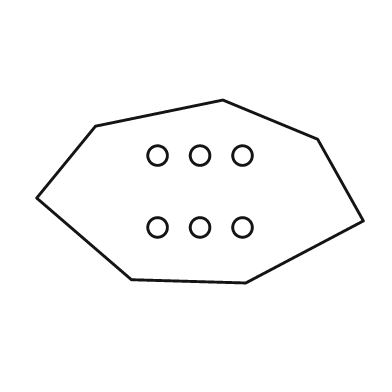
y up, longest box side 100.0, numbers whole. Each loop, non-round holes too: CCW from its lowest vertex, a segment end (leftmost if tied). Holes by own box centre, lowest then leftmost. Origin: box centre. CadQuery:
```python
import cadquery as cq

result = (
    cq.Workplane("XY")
    .moveTo(14.0, -28.0)
    .lineTo(50.0, -9.0)
    .lineTo(36.0, 16.0)
    .lineTo(7.0, 28.0)
    .lineTo(-32.0, 20.0)
    .lineTo(-50.0, -2.0)
    .lineTo(-21.0, -27.0)
    .close()
    .moveTo(-13.0, -11.0)
    .circle(3.0)
    .moveTo(0.0, -11.0)
    .circle(3.0)
    .moveTo(13.0, -11.0)
    .circle(3.0)
    .moveTo(-13.0, 11.0)
    .circle(3.0)
    .moveTo(0.0, 11.0)
    .circle(3.0)
    .moveTo(13.0, 11.0)
    .circle(3.0)
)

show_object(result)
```